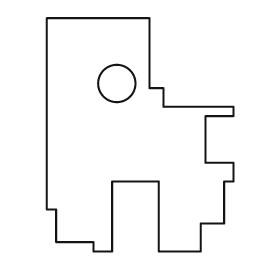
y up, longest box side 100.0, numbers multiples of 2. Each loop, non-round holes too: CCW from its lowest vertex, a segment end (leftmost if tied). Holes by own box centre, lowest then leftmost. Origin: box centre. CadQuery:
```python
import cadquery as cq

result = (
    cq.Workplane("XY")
    .moveTo(-20.0, -50.0)
    .lineTo(-12.0, -50.0)
    .lineTo(-12.0, -20.0)
    .lineTo(8.0, -20.0)
    .lineTo(8.0, -50.0)
    .lineTo(26.0, -50.0)
    .lineTo(26.0, -38.0)
    .lineTo(36.0, -38.0)
    .lineTo(36.0, -20.0)
    .lineTo(40.0, -20.0)
    .lineTo(40.0, -12.0)
    .lineTo(28.0, -12.0)
    .lineTo(28.0, 8.0)
    .lineTo(40.0, 8.0)
    .lineTo(40.0, 12.0)
    .lineTo(10.0, 12.0)
    .lineTo(10.0, 20.0)
    .lineTo(4.0, 20.0)
    .lineTo(4.0, 50.0)
    .lineTo(-40.0, 50.0)
    .lineTo(-40.0, -32.0)
    .lineTo(-36.0, -32.0)
    .lineTo(-36.0, -46.0)
    .lineTo(-20.0, -46.0)
    .close()
    .moveTo(-10.0, 22.0)
    .circle(8.0)
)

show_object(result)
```